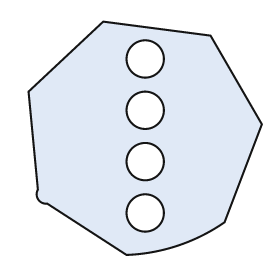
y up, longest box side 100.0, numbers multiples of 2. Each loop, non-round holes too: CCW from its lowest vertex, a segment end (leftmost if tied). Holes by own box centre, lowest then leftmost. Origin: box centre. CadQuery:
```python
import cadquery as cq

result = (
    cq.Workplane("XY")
    .moveTo(-8.0, -50.0)
    .threePointArc((14.0, -46.0), (34.0, -36.0))
    .lineTo(50.0, 6.0)
    .lineTo(28.0, 44.0)
    .lineTo(-18.0, 50.0)
    .lineTo(-50.0, 20.0)
    .lineTo(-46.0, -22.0)
    .threePointArc((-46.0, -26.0), (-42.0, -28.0))
    .close()
    .moveTo(0.0, -32.0)
    .circle(8.0)
    .moveTo(0.0, -10.0)
    .circle(8.0)
    .moveTo(0.0, 12.0)
    .circle(8.0)
    .moveTo(0.0, 34.0)
    .circle(8.0)
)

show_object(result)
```